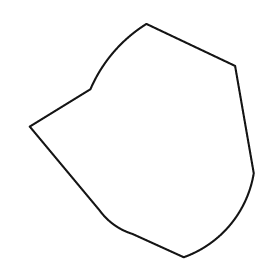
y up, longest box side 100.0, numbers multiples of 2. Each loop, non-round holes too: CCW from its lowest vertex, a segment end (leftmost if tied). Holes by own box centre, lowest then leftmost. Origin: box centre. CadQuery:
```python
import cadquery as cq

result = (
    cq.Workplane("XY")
    .moveTo(18.0, -50.0)
    .threePointArc((38.0, -36.0), (48.0, -14.0))
    .lineTo(40.0, 32.0)
    .lineTo(2.0, 50.0)
    .threePointArc((-12.0, 38.0), (-22.0, 22.0))
    .lineTo(-48.0, 6.0)
    .lineTo(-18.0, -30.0)
    .threePointArc((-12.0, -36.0), (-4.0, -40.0))
    .close()
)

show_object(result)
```